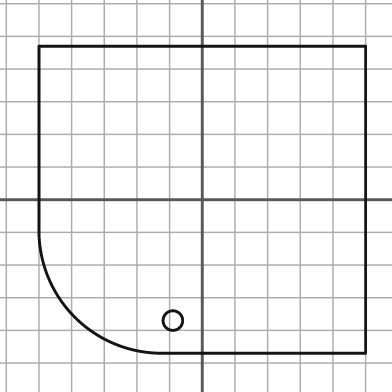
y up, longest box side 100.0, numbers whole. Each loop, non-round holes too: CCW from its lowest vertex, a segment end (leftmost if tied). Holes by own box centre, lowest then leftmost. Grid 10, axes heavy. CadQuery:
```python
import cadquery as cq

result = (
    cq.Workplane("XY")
    .moveTo(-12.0, -47.0)
    .lineTo(50.0, -47.0)
    .lineTo(50.0, 47.0)
    .lineTo(-50.0, 47.0)
    .lineTo(-50.0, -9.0)
    .threePointArc((-39.0, -36.0), (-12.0, -47.0))
    .close()
    .moveTo(-9.0, -37.0)
    .circle(3.0)
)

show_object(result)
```